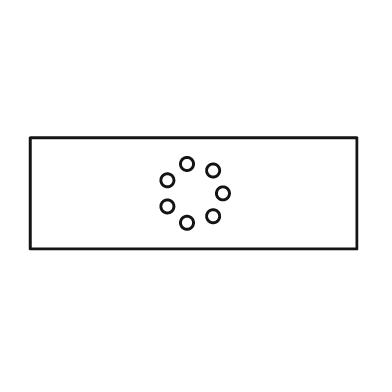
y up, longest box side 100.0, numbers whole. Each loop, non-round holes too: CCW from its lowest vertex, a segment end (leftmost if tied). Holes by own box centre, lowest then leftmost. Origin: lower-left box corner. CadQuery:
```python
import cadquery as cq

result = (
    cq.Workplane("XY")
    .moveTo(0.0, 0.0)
    .lineTo(100.0, 0.0)
    .lineTo(100.0, 34.0)
    .lineTo(0.0, 34.0)
    .close()
    .moveTo(48.0, 8.0)
    .circle(2.0)
    .moveTo(56.0, 10.0)
    .circle(2.0)
    .moveTo(42.0, 13.0)
    .circle(2.0)
    .moveTo(59.0, 17.0)
    .circle(2.0)
    .moveTo(42.0, 21.0)
    .circle(2.0)
    .moveTo(56.0, 24.0)
    .circle(2.0)
    .moveTo(48.0, 26.0)
    .circle(2.0)
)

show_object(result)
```